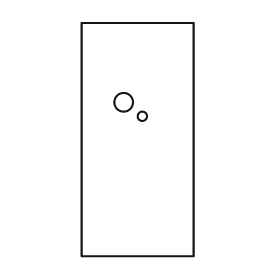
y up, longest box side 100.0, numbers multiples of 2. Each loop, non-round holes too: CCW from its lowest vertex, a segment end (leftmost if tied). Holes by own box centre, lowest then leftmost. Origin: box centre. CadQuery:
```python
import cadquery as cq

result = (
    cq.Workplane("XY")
    .moveTo(-24.0, -50.0)
    .lineTo(24.0, -50.0)
    .lineTo(24.0, 50.0)
    .lineTo(-24.0, 50.0)
    .close()
    .moveTo(2.0, 10.0)
    .circle(2.0)
    .moveTo(-6.0, 16.0)
    .circle(4.0)
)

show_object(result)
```